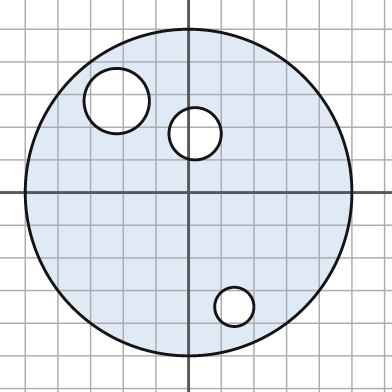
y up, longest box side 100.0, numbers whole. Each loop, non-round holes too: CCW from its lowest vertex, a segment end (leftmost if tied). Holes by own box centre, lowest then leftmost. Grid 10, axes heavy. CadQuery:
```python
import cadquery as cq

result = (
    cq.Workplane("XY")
    .moveTo(0.0, 0.0)
    .circle(50.0)
    .moveTo(14.0, -35.0)
    .circle(6.0)
    .moveTo(2.0, 18.0)
    .circle(8.0)
    .moveTo(-22.0, 28.0)
    .circle(10.0)
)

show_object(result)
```